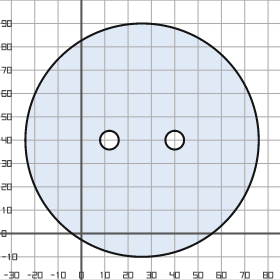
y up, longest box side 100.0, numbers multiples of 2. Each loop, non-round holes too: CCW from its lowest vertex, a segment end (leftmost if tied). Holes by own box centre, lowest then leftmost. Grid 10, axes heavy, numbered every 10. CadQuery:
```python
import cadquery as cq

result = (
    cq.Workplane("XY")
    .moveTo(26.0, 40.0)
    .circle(50.0)
    .moveTo(12.0, 40.0)
    .circle(4.0)
    .moveTo(40.0, 40.0)
    .circle(4.0)
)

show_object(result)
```